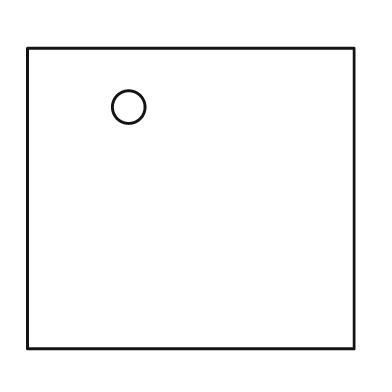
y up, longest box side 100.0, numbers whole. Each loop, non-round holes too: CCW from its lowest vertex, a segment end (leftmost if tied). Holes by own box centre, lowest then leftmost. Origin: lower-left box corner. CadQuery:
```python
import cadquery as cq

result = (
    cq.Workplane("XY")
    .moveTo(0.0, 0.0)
    .lineTo(100.0, 0.0)
    .lineTo(100.0, 92.0)
    .lineTo(0.0, 92.0)
    .close()
    .moveTo(31.0, 74.0)
    .circle(5.0)
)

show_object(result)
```